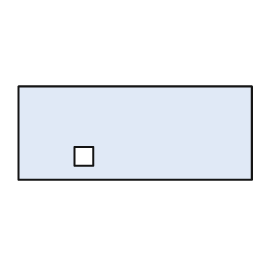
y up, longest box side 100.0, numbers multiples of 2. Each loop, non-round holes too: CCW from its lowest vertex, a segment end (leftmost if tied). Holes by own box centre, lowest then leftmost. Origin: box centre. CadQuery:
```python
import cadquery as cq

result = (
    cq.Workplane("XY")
    .moveTo(-50.0, -20.0)
    .lineTo(50.0, -20.0)
    .lineTo(50.0, 20.0)
    .lineTo(-50.0, 20.0)
    .close()
    .moveTo(-26.0, -14.0)
    .lineTo(-18.0, -14.0)
    .lineTo(-18.0, -6.0)
    .lineTo(-26.0, -6.0)
    .close()
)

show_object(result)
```